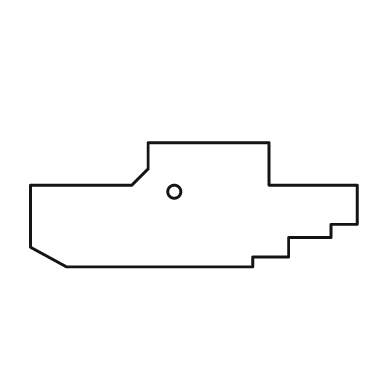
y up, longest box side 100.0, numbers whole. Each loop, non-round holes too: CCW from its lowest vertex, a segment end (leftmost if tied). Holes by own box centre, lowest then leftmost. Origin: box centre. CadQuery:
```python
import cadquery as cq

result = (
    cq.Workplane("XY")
    .moveTo(-39.0, -19.0)
    .lineTo(18.0, -19.0)
    .lineTo(18.0, -16.0)
    .lineTo(29.0, -16.0)
    .lineTo(29.0, -10.0)
    .lineTo(42.0, -10.0)
    .lineTo(42.0, -6.0)
    .lineTo(50.0, -6.0)
    .lineTo(50.0, 6.0)
    .lineTo(23.0, 6.0)
    .lineTo(23.0, 19.0)
    .lineTo(-14.0, 19.0)
    .lineTo(-14.0, 11.0)
    .lineTo(-19.0, 6.0)
    .lineTo(-50.0, 6.0)
    .lineTo(-50.0, -13.0)
    .close()
    .moveTo(-6.0, 4.0)
    .circle(2.0)
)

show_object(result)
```